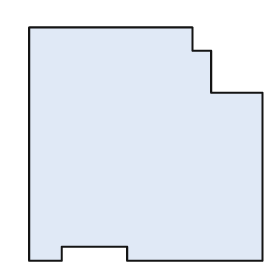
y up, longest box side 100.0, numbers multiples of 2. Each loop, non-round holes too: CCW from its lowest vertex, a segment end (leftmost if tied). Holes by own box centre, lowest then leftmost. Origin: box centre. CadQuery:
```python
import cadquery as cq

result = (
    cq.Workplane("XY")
    .moveTo(-50.0, -50.0)
    .lineTo(-36.0, -50.0)
    .lineTo(-36.0, -44.0)
    .lineTo(-8.0, -44.0)
    .lineTo(-8.0, -50.0)
    .lineTo(50.0, -50.0)
    .lineTo(50.0, 22.0)
    .lineTo(28.0, 22.0)
    .lineTo(28.0, 40.0)
    .lineTo(20.0, 40.0)
    .lineTo(20.0, 50.0)
    .lineTo(-50.0, 50.0)
    .close()
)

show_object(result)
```